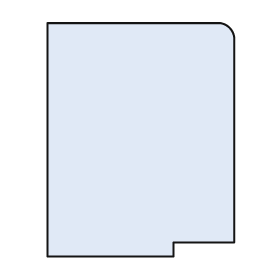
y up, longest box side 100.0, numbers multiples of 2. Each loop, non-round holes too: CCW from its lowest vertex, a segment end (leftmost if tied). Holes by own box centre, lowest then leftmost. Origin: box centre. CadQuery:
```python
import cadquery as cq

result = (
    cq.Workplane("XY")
    .moveTo(-40.0, -50.0)
    .lineTo(14.0, -50.0)
    .lineTo(14.0, -44.0)
    .lineTo(40.0, -44.0)
    .lineTo(40.0, 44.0)
    .threePointArc((38.0, 48.0), (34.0, 50.0))
    .lineTo(-40.0, 50.0)
    .close()
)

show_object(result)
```